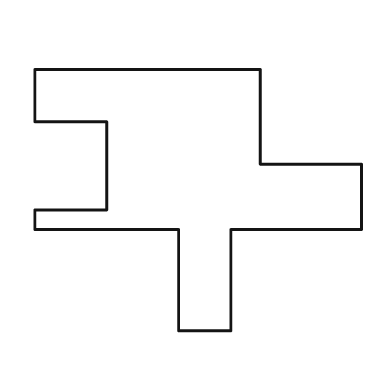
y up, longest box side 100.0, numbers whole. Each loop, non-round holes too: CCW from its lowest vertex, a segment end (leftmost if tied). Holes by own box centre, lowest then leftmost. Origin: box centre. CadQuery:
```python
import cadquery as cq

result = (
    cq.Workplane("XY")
    .moveTo(-6.0, -40.0)
    .lineTo(10.0, -40.0)
    .lineTo(10.0, -9.0)
    .lineTo(50.0, -9.0)
    .lineTo(50.0, 11.0)
    .lineTo(19.0, 11.0)
    .lineTo(19.0, 40.0)
    .lineTo(-50.0, 40.0)
    .lineTo(-50.0, 24.0)
    .lineTo(-28.0, 24.0)
    .lineTo(-28.0, -3.0)
    .lineTo(-50.0, -3.0)
    .lineTo(-50.0, -9.0)
    .lineTo(-6.0, -9.0)
    .close()
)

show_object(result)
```